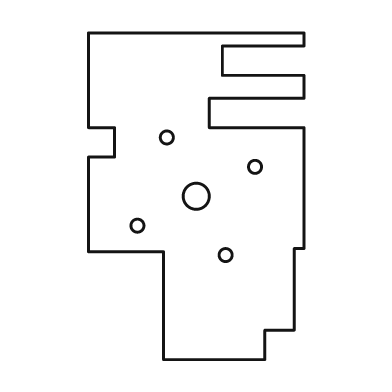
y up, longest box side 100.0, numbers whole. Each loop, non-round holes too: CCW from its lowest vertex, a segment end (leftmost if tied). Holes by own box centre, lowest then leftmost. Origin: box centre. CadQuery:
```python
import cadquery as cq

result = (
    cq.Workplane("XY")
    .moveTo(-10.0, -50.0)
    .lineTo(21.0, -50.0)
    .lineTo(21.0, -41.0)
    .lineTo(30.0, -41.0)
    .lineTo(30.0, -16.0)
    .lineTo(33.0, -16.0)
    .lineTo(33.0, 21.0)
    .lineTo(4.0, 21.0)
    .lineTo(4.0, 30.0)
    .lineTo(33.0, 30.0)
    .lineTo(33.0, 37.0)
    .lineTo(8.0, 37.0)
    .lineTo(8.0, 46.0)
    .lineTo(33.0, 46.0)
    .lineTo(33.0, 50.0)
    .lineTo(-33.0, 50.0)
    .lineTo(-33.0, 21.0)
    .lineTo(-25.0, 21.0)
    .lineTo(-25.0, 12.0)
    .lineTo(-33.0, 12.0)
    .lineTo(-33.0, -17.0)
    .lineTo(-10.0, -17.0)
    .close()
    .moveTo(9.0, -18.0)
    .circle(2.0)
    .moveTo(-18.0, -9.0)
    .circle(2.0)
    .moveTo(0.0, 0.0)
    .circle(4.0)
    .moveTo(18.0, 9.0)
    .circle(2.0)
    .moveTo(-9.0, 18.0)
    .circle(2.0)
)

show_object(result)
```